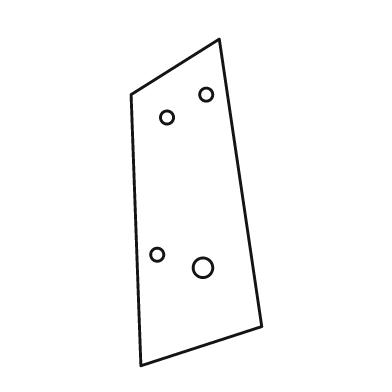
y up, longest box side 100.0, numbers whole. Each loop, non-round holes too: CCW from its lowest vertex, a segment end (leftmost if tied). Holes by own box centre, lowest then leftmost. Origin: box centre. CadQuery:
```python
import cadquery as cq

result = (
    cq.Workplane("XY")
    .moveTo(-17.0, -50.0)
    .lineTo(20.0, -38.0)
    .lineTo(7.0, 50.0)
    .lineTo(-20.0, 33.0)
    .close()
    .moveTo(2.0, -20.0)
    .circle(3.0)
    .moveTo(-12.0, -16.0)
    .circle(2.0)
    .moveTo(-9.0, 26.0)
    .circle(2.0)
    .moveTo(3.0, 33.0)
    .circle(2.0)
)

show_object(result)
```